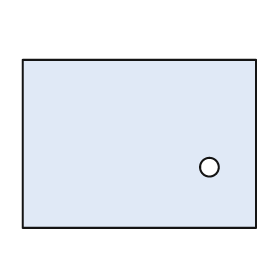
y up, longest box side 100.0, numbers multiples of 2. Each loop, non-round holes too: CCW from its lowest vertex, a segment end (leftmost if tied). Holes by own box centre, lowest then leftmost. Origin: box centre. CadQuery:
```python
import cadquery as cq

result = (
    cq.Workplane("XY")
    .moveTo(-50.0, -36.0)
    .lineTo(50.0, -36.0)
    .lineTo(50.0, 36.0)
    .lineTo(-50.0, 36.0)
    .close()
    .moveTo(30.0, -10.0)
    .circle(4.0)
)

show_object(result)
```